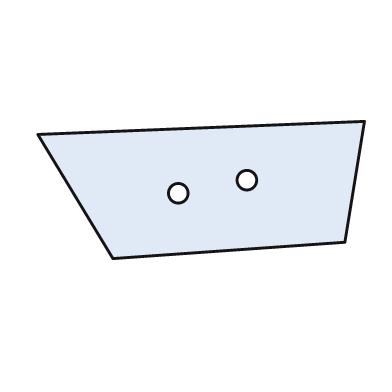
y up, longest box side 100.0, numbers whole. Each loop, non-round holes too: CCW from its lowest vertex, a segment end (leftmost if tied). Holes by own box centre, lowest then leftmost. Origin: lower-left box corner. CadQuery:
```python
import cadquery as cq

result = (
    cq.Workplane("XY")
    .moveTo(23.0, 0.0)
    .lineTo(94.0, 5.0)
    .lineTo(100.0, 42.0)
    .lineTo(0.0, 38.0)
    .close()
    .moveTo(43.0, 20.0)
    .circle(3.0)
    .moveTo(64.0, 24.0)
    .circle(3.0)
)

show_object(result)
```